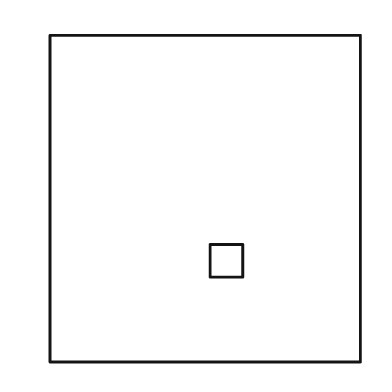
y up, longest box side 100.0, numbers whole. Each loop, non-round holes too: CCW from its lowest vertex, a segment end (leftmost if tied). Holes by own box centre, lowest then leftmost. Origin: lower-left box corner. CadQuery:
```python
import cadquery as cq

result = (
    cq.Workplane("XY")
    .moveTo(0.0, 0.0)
    .lineTo(95.0, 0.0)
    .lineTo(95.0, 100.0)
    .lineTo(0.0, 100.0)
    .close()
    .moveTo(49.0, 26.0)
    .lineTo(59.0, 26.0)
    .lineTo(59.0, 36.0)
    .lineTo(49.0, 36.0)
    .close()
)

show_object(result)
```